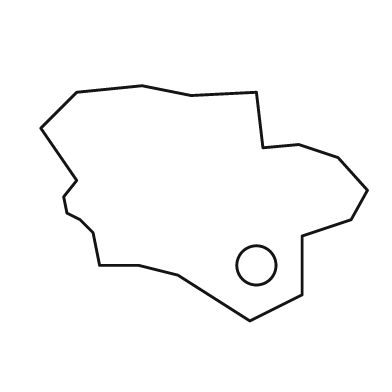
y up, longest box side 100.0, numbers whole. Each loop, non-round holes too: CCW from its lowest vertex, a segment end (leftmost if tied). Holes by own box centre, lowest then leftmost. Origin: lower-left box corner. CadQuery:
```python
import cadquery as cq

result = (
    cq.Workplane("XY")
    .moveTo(64.0, 0.0)
    .lineTo(80.0, 8.0)
    .lineTo(80.0, 26.0)
    .lineTo(95.0, 31.0)
    .lineTo(100.0, 40.0)
    .lineTo(91.0, 50.0)
    .lineTo(79.0, 54.0)
    .lineTo(68.0, 53.0)
    .lineTo(66.0, 70.0)
    .lineTo(46.0, 69.0)
    .lineTo(31.0, 72.0)
    .lineTo(11.0, 70.0)
    .lineTo(0.0, 59.0)
    .lineTo(11.0, 43.0)
    .lineTo(7.0, 38.0)
    .lineTo(8.0, 33.0)
    .lineTo(12.0, 31.0)
    .lineTo(16.0, 27.0)
    .lineTo(18.0, 17.0)
    .lineTo(30.0, 17.0)
    .lineTo(42.0, 14.0)
    .close()
    .moveTo(66.0, 17.0)
    .circle(6.0)
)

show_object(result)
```